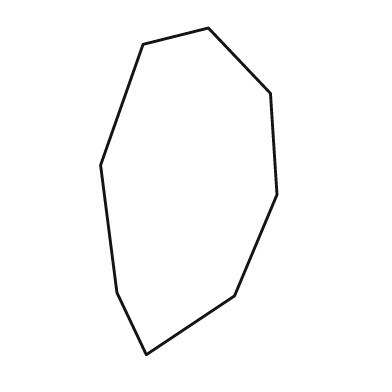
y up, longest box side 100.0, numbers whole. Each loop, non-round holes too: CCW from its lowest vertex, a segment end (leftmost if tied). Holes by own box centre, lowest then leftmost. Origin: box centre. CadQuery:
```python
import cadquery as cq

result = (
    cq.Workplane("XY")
    .moveTo(-13.0, -50.0)
    .lineTo(14.0, -32.0)
    .lineTo(27.0, -1.0)
    .lineTo(25.0, 30.0)
    .lineTo(6.0, 50.0)
    .lineTo(-14.0, 45.0)
    .lineTo(-27.0, 8.0)
    .lineTo(-22.0, -31.0)
    .close()
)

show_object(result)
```